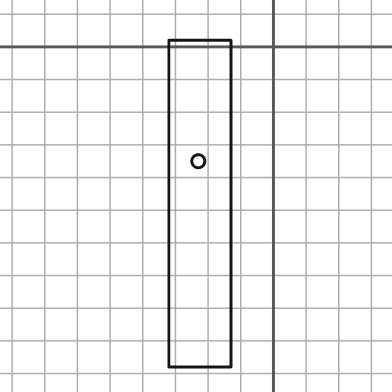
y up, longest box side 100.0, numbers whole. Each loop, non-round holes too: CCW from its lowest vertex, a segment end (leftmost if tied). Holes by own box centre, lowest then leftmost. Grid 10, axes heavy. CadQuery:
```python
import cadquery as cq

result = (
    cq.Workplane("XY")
    .moveTo(-32.0, -98.0)
    .lineTo(-13.0, -98.0)
    .lineTo(-13.0, 2.0)
    .lineTo(-32.0, 2.0)
    .close()
    .moveTo(-23.0, -35.0)
    .circle(2.0)
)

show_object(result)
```